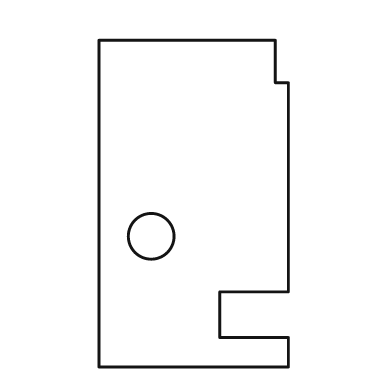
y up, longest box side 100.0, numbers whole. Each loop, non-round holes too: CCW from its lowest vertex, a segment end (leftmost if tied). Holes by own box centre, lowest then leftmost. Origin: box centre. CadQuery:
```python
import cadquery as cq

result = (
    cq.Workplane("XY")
    .moveTo(-29.0, -50.0)
    .lineTo(29.0, -50.0)
    .lineTo(29.0, -41.0)
    .lineTo(8.0, -41.0)
    .lineTo(8.0, -27.0)
    .lineTo(29.0, -27.0)
    .lineTo(29.0, 37.0)
    .lineTo(25.0, 37.0)
    .lineTo(25.0, 50.0)
    .lineTo(-29.0, 50.0)
    .close()
    .moveTo(-13.0, -10.0)
    .circle(7.0)
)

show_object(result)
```